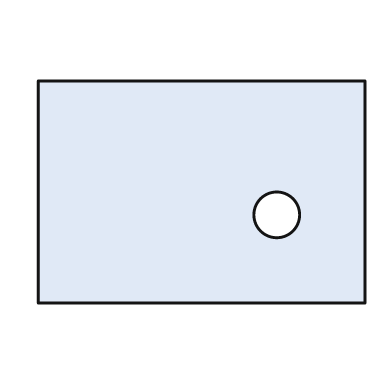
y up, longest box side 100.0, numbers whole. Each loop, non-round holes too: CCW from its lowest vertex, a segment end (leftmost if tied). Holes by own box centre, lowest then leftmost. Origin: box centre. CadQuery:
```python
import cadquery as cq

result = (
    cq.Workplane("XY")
    .moveTo(-50.0, -34.0)
    .lineTo(50.0, -34.0)
    .lineTo(50.0, 34.0)
    .lineTo(-50.0, 34.0)
    .close()
    .moveTo(23.0, -7.0)
    .circle(7.0)
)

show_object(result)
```